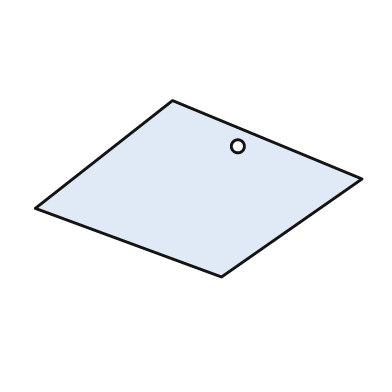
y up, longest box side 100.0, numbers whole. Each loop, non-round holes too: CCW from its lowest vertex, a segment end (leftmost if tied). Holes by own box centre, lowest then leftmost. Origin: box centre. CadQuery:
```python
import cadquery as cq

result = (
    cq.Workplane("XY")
    .moveTo(7.0, -27.0)
    .lineTo(50.0, 3.0)
    .lineTo(-8.0, 27.0)
    .lineTo(-50.0, -6.0)
    .close()
    .moveTo(12.0, 13.0)
    .circle(2.0)
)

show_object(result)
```